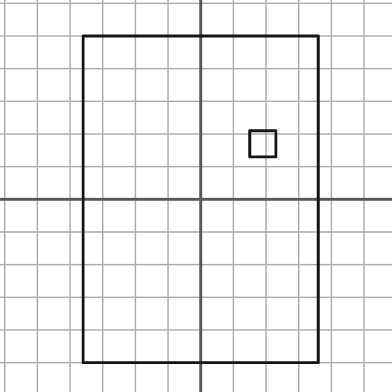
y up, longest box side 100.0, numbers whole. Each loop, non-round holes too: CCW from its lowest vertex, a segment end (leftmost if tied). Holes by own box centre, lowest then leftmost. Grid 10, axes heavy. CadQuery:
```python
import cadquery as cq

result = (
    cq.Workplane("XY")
    .moveTo(-36.0, -50.0)
    .lineTo(36.0, -50.0)
    .lineTo(36.0, 50.0)
    .lineTo(-36.0, 50.0)
    .close()
    .moveTo(15.0, 13.0)
    .lineTo(23.0, 13.0)
    .lineTo(23.0, 21.0)
    .lineTo(15.0, 21.0)
    .close()
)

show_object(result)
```